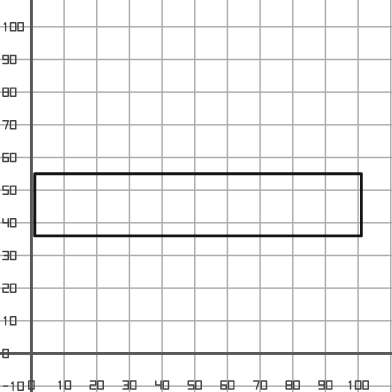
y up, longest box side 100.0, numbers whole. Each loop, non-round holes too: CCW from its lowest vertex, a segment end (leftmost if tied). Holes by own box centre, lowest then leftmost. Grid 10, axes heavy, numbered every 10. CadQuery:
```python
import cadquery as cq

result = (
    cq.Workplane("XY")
    .moveTo(1.0, 36.0)
    .lineTo(101.0, 36.0)
    .lineTo(101.0, 55.0)
    .lineTo(1.0, 55.0)
    .close()
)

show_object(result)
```